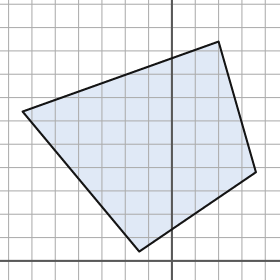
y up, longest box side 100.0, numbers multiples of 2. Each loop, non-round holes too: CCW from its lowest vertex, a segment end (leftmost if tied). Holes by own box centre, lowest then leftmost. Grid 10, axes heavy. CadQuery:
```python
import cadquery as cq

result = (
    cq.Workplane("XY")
    .moveTo(-14.0, 4.0)
    .lineTo(36.0, 38.0)
    .lineTo(20.0, 94.0)
    .lineTo(-64.0, 64.0)
    .close()
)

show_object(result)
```